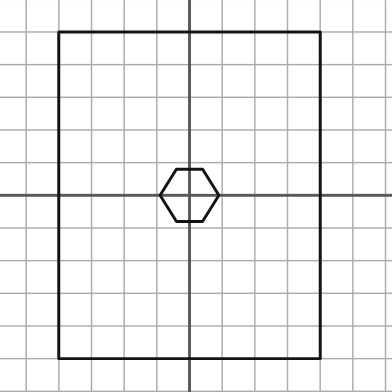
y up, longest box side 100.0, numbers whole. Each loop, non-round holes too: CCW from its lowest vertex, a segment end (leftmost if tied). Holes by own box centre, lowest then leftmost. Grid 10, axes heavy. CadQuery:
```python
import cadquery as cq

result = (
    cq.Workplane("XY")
    .moveTo(-40.0, -50.0)
    .lineTo(40.0, -50.0)
    .lineTo(40.0, 50.0)
    .lineTo(-40.0, 50.0)
    .close()
    .moveTo(-4.0, -8.0)
    .lineTo(4.0, -8.0)
    .lineTo(9.0, 0.0)
    .lineTo(4.0, 8.0)
    .lineTo(-4.0, 8.0)
    .lineTo(-9.0, 0.0)
    .close()
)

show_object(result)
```